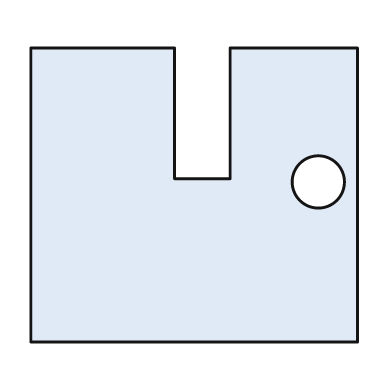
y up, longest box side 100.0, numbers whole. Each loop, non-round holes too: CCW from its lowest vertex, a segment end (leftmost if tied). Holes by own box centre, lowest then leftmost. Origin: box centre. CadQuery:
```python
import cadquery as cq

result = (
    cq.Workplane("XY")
    .moveTo(-50.0, -45.0)
    .lineTo(50.0, -45.0)
    .lineTo(50.0, 45.0)
    .lineTo(11.0, 45.0)
    .lineTo(11.0, 5.0)
    .lineTo(-6.0, 5.0)
    .lineTo(-6.0, 45.0)
    .lineTo(-50.0, 45.0)
    .close()
    .moveTo(38.0, 4.0)
    .circle(8.0)
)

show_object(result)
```